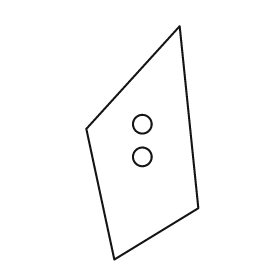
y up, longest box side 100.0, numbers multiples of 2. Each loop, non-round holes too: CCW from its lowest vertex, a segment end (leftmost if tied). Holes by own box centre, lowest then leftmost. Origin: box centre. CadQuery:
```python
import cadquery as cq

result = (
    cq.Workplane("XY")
    .moveTo(-12.0, -50.0)
    .lineTo(24.0, -28.0)
    .lineTo(16.0, 50.0)
    .lineTo(-24.0, 6.0)
    .close()
    .moveTo(0.0, -6.0)
    .circle(4.0)
    .moveTo(0.0, 8.0)
    .circle(4.0)
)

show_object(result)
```